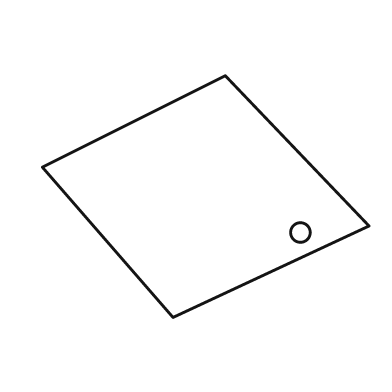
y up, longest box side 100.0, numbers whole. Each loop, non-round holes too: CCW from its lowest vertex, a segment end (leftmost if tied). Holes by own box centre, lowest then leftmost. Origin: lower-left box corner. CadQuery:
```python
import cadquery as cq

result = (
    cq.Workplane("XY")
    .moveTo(40.0, 0.0)
    .lineTo(100.0, 28.0)
    .lineTo(56.0, 74.0)
    .lineTo(0.0, 46.0)
    .close()
    .moveTo(79.0, 26.0)
    .circle(3.0)
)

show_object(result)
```